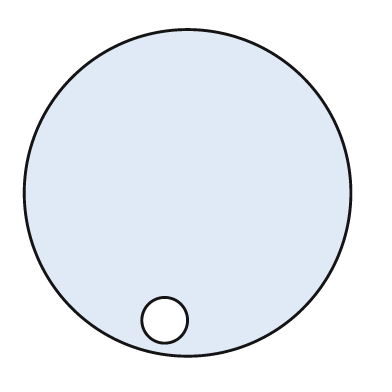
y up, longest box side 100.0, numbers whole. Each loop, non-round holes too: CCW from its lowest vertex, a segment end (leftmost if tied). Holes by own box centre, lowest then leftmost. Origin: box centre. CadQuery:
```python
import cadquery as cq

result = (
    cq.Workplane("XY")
    .moveTo(0.0, 0.0)
    .circle(50.0)
    .moveTo(-7.0, -39.0)
    .circle(7.0)
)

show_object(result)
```